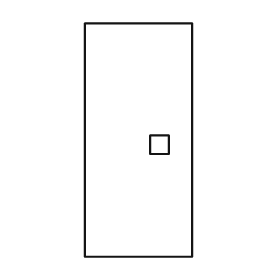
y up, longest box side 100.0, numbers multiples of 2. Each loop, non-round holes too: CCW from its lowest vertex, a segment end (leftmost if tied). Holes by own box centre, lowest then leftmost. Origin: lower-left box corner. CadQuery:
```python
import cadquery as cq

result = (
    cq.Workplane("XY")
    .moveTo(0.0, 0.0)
    .lineTo(46.0, 0.0)
    .lineTo(46.0, 100.0)
    .lineTo(0.0, 100.0)
    .close()
    .moveTo(28.0, 44.0)
    .lineTo(36.0, 44.0)
    .lineTo(36.0, 52.0)
    .lineTo(28.0, 52.0)
    .close()
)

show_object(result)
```